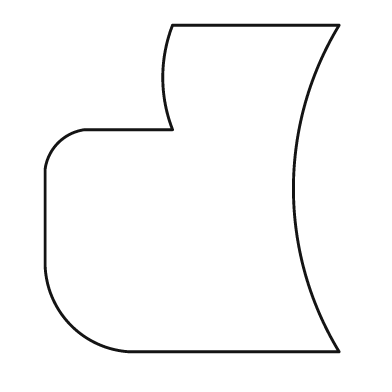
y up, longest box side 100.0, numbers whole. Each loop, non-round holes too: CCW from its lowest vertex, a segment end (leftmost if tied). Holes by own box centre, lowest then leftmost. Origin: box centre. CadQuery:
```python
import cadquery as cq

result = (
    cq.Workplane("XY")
    .moveTo(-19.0, -50.0)
    .lineTo(45.0, -50.0)
    .threePointArc((31.0, 0.0), (45.0, 50.0))
    .lineTo(-6.0, 50.0)
    .threePointArc((-9.0, 34.0), (-6.0, 18.0))
    .lineTo(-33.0, 18.0)
    .threePointArc((-41.0, 14.0), (-45.0, 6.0))
    .lineTo(-45.0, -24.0)
    .threePointArc((-37.0, -42.0), (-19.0, -50.0))
    .close()
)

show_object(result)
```